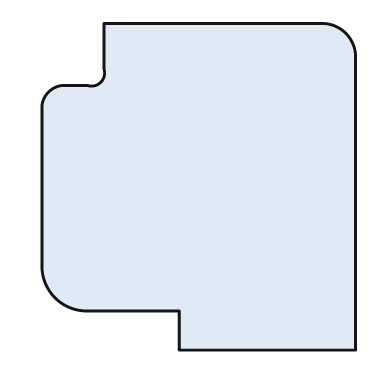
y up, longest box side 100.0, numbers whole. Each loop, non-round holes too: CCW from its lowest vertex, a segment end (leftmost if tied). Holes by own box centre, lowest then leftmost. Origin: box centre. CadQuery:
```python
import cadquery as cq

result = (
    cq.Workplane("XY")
    .moveTo(-6.0, -50.0)
    .lineTo(48.0, -50.0)
    .lineTo(48.0, 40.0)
    .threePointArc((45.0, 47.0), (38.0, 50.0))
    .lineTo(-29.0, 50.0)
    .lineTo(-29.0, 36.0)
    .threePointArc((-30.0, 32.0), (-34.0, 31.0))
    .lineTo(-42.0, 31.0)
    .threePointArc((-46.0, 29.0), (-48.0, 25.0))
    .lineTo(-48.0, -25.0)
    .threePointArc((-44.0, -34.0), (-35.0, -38.0))
    .lineTo(-6.0, -38.0)
    .close()
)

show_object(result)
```